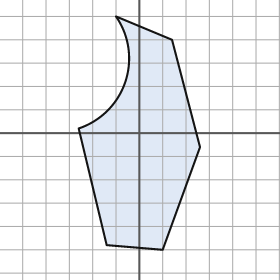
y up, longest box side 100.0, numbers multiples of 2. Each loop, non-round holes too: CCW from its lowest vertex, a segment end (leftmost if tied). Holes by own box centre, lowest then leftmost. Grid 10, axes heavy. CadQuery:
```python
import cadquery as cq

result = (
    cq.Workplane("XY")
    .moveTo(10.0, -50.0)
    .lineTo(26.0, -6.0)
    .lineTo(14.0, 40.0)
    .lineTo(-10.0, 50.0)
    .threePointArc((-6.0, 22.0), (-26.0, 2.0))
    .lineTo(-14.0, -48.0)
    .close()
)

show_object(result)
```